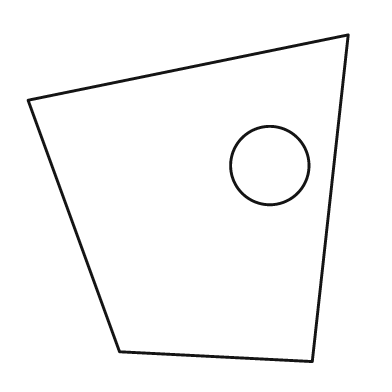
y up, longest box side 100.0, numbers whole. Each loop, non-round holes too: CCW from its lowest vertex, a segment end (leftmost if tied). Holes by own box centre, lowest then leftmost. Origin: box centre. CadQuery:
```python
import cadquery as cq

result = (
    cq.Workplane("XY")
    .moveTo(38.0, -50.0)
    .lineTo(49.0, 50.0)
    .lineTo(-49.0, 30.0)
    .lineTo(-21.0, -47.0)
    .close()
    .moveTo(25.0, 10.0)
    .circle(12.0)
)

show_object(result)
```